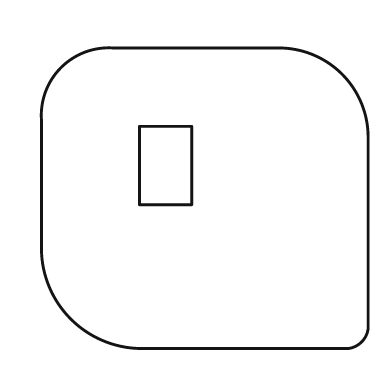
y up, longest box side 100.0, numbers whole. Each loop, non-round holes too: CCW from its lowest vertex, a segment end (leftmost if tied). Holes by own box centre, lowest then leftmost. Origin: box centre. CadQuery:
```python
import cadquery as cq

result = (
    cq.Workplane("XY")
    .moveTo(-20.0, -46.0)
    .lineTo(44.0, -46.0)
    .threePointArc((48.0, -44.0), (50.0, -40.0))
    .lineTo(50.0, 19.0)
    .threePointArc((42.0, 38.0), (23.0, 46.0))
    .lineTo(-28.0, 46.0)
    .threePointArc((-44.0, 40.0), (-50.0, 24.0))
    .lineTo(-50.0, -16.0)
    .threePointArc((-41.0, -37.0), (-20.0, -46.0))
    .close()
    .moveTo(-20.0, -2.0)
    .lineTo(-4.0, -2.0)
    .lineTo(-4.0, 22.0)
    .lineTo(-20.0, 22.0)
    .close()
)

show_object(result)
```